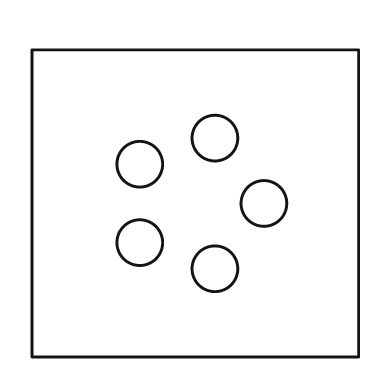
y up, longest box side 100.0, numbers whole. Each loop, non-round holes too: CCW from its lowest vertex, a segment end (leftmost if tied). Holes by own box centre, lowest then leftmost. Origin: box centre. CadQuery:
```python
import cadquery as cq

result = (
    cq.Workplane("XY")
    .moveTo(-50.0, -47.0)
    .lineTo(50.0, -47.0)
    .lineTo(50.0, 47.0)
    .lineTo(-50.0, 47.0)
    .close()
    .moveTo(6.0, -20.0)
    .circle(7.0)
    .moveTo(-17.0, -12.0)
    .circle(7.0)
    .moveTo(21.0, 0.0)
    .circle(7.0)
    .moveTo(-17.0, 12.0)
    .circle(7.0)
    .moveTo(6.0, 20.0)
    .circle(7.0)
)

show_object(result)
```